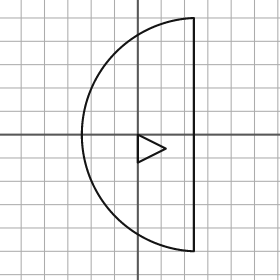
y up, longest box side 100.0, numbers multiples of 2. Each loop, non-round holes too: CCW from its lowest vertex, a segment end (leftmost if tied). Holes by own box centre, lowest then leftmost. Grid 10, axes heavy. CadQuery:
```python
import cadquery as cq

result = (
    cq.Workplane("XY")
    .moveTo(24.0, -50.0)
    .lineTo(24.0, 50.0)
    .threePointArc((-24.0, 0.0), (24.0, -50.0))
    .close()
    .moveTo(0.0, -12.0)
    .lineTo(12.0, -6.0)
    .lineTo(0.0, 0.0)
    .close()
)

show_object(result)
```